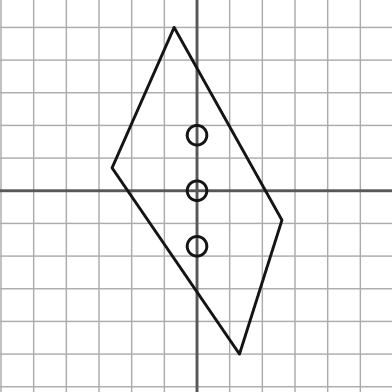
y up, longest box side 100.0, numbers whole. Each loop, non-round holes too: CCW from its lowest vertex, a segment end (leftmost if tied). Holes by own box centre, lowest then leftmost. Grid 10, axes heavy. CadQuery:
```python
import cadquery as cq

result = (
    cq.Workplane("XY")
    .moveTo(13.0, -50.0)
    .lineTo(26.0, -9.0)
    .lineTo(-7.0, 50.0)
    .lineTo(-26.0, 7.0)
    .close()
    .moveTo(0.0, -17.0)
    .circle(3.0)
    .moveTo(0.0, 0.0)
    .circle(3.0)
    .moveTo(0.0, 17.0)
    .circle(3.0)
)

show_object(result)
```